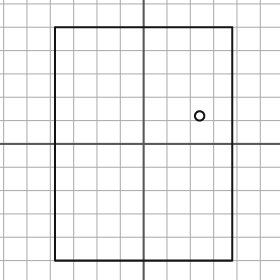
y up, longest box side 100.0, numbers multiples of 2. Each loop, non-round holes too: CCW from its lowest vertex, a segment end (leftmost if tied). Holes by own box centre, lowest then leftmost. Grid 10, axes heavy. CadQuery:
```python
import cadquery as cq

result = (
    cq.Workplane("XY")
    .moveTo(-38.0, -50.0)
    .lineTo(38.0, -50.0)
    .lineTo(38.0, 50.0)
    .lineTo(-38.0, 50.0)
    .close()
    .moveTo(24.0, 12.0)
    .circle(2.0)
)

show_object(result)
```